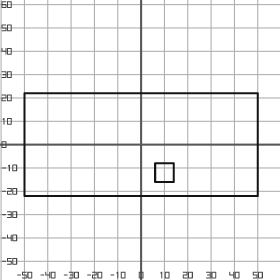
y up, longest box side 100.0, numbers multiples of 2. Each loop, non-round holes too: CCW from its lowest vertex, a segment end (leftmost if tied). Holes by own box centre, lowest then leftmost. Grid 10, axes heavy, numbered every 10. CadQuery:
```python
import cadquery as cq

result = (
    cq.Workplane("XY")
    .moveTo(-50.0, -22.0)
    .lineTo(50.0, -22.0)
    .lineTo(50.0, 22.0)
    .lineTo(-50.0, 22.0)
    .close()
    .moveTo(6.0, -16.0)
    .lineTo(14.0, -16.0)
    .lineTo(14.0, -8.0)
    .lineTo(6.0, -8.0)
    .close()
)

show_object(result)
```